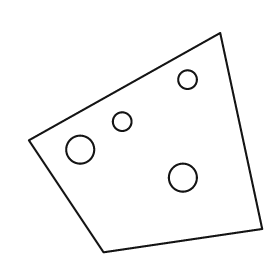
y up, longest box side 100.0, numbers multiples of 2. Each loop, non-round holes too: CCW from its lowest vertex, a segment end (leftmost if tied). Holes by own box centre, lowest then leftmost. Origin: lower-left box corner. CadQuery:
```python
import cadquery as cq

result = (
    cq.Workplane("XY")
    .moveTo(32.0, 0.0)
    .lineTo(100.0, 10.0)
    .lineTo(82.0, 94.0)
    .lineTo(0.0, 48.0)
    .close()
    .moveTo(66.0, 32.0)
    .circle(6.0)
    .moveTo(22.0, 44.0)
    .circle(6.0)
    .moveTo(40.0, 56.0)
    .circle(4.0)
    .moveTo(68.0, 74.0)
    .circle(4.0)
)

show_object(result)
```